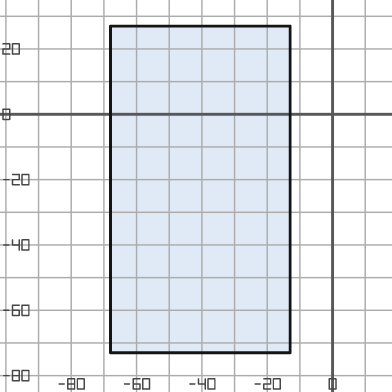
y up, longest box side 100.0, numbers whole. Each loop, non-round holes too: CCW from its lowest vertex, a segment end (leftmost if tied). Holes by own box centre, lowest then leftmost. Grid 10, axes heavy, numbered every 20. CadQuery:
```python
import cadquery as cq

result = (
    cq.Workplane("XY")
    .moveTo(-68.0, -73.0)
    .lineTo(-13.0, -73.0)
    .lineTo(-13.0, 27.0)
    .lineTo(-68.0, 27.0)
    .close()
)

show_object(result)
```